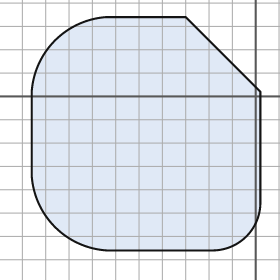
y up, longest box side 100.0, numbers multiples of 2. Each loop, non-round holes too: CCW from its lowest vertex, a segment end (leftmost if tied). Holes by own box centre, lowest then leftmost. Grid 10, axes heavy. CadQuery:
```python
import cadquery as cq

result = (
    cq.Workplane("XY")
    .moveTo(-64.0, -66.0)
    .lineTo(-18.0, -66.0)
    .threePointArc((-4.0, -60.0), (2.0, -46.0))
    .lineTo(2.0, 2.0)
    .lineTo(-30.0, 34.0)
    .lineTo(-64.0, 34.0)
    .threePointArc((-86.0, 24.0), (-96.0, 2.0))
    .lineTo(-96.0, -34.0)
    .threePointArc((-86.0, -56.0), (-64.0, -66.0))
    .close()
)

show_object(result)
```